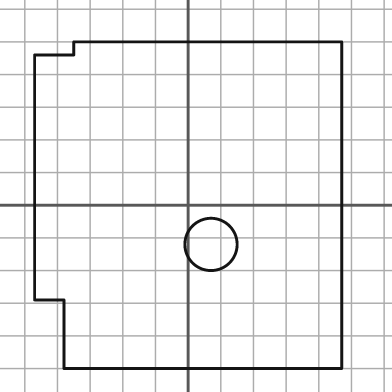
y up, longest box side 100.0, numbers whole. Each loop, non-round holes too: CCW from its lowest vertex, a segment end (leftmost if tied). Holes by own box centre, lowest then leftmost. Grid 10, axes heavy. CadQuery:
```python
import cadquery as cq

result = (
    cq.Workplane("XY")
    .moveTo(-38.0, -50.0)
    .lineTo(47.0, -50.0)
    .lineTo(47.0, 50.0)
    .lineTo(-35.0, 50.0)
    .lineTo(-35.0, 46.0)
    .lineTo(-47.0, 46.0)
    .lineTo(-47.0, -29.0)
    .lineTo(-38.0, -29.0)
    .close()
    .moveTo(7.0, -12.0)
    .circle(8.0)
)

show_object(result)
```